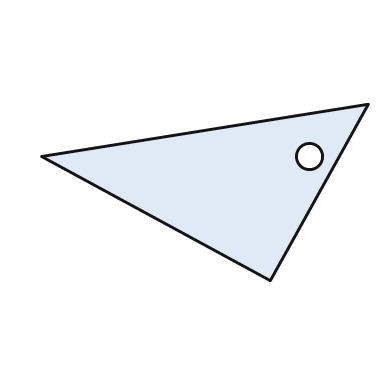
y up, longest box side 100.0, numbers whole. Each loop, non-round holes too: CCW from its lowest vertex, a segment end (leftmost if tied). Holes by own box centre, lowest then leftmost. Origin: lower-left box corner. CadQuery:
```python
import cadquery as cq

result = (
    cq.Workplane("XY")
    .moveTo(70.0, 0.0)
    .lineTo(100.0, 54.0)
    .lineTo(0.0, 38.0)
    .close()
    .moveTo(82.0, 38.0)
    .circle(4.0)
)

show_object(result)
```